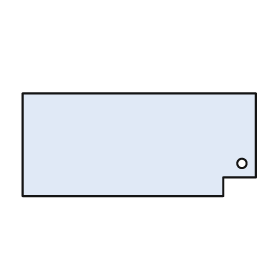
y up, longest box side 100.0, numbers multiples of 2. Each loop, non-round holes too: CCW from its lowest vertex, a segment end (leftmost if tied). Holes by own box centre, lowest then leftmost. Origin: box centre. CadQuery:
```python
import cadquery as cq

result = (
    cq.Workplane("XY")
    .moveTo(-50.0, -22.0)
    .lineTo(36.0, -22.0)
    .lineTo(36.0, -14.0)
    .lineTo(50.0, -14.0)
    .lineTo(50.0, 22.0)
    .lineTo(-50.0, 22.0)
    .close()
    .moveTo(44.0, -8.0)
    .circle(2.0)
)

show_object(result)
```